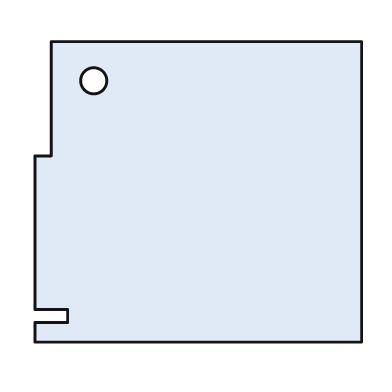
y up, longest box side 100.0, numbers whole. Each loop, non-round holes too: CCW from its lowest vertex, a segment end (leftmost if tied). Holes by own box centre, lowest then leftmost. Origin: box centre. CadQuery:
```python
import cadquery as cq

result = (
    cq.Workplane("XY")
    .moveTo(-50.0, -46.0)
    .lineTo(50.0, -46.0)
    .lineTo(50.0, 46.0)
    .lineTo(-45.0, 46.0)
    .lineTo(-45.0, 11.0)
    .lineTo(-50.0, 11.0)
    .lineTo(-50.0, -36.0)
    .lineTo(-40.0, -36.0)
    .lineTo(-40.0, -40.0)
    .lineTo(-50.0, -40.0)
    .close()
    .moveTo(-32.0, 34.0)
    .circle(4.0)
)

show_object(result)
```